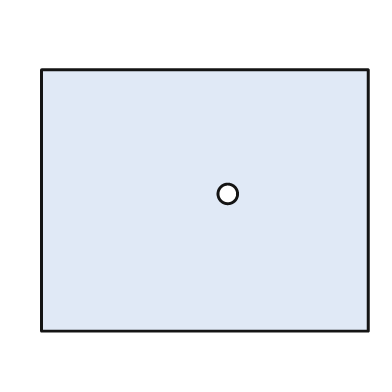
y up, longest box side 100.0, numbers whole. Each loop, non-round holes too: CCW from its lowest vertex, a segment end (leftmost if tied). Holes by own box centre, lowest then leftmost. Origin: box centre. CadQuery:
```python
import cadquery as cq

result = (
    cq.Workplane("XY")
    .moveTo(-50.0, -40.0)
    .lineTo(50.0, -40.0)
    .lineTo(50.0, 40.0)
    .lineTo(-50.0, 40.0)
    .close()
    .moveTo(7.0, 2.0)
    .circle(3.0)
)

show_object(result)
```